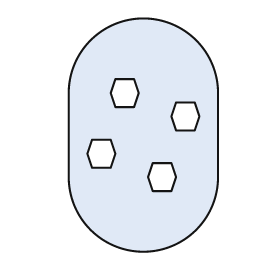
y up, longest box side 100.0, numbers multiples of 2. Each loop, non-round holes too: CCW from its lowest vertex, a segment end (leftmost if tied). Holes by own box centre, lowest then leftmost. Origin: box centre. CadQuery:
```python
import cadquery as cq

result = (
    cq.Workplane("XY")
    .moveTo(-32.0, -18.0)
    .threePointArc((0.0, -50.0), (32.0, -18.0))
    .lineTo(32.0, 18.0)
    .threePointArc((0.0, 50.0), (-32.0, 18.0))
    .close()
    .moveTo(4.0, -24.0)
    .lineTo(12.0, -24.0)
    .lineTo(14.0, -18.0)
    .lineTo(12.0, -12.0)
    .lineTo(4.0, -12.0)
    .lineTo(2.0, -18.0)
    .close()
    .moveTo(-22.0, -14.0)
    .lineTo(-14.0, -14.0)
    .lineTo(-12.0, -8.0)
    .lineTo(-14.0, -2.0)
    .lineTo(-22.0, -2.0)
    .lineTo(-24.0, -8.0)
    .close()
    .moveTo(14.0, 2.0)
    .lineTo(22.0, 2.0)
    .lineTo(24.0, 8.0)
    .lineTo(22.0, 14.0)
    .lineTo(14.0, 14.0)
    .lineTo(12.0, 8.0)
    .close()
    .moveTo(-12.0, 12.0)
    .lineTo(-4.0, 12.0)
    .lineTo(-2.0, 18.0)
    .lineTo(-4.0, 24.0)
    .lineTo(-12.0, 24.0)
    .lineTo(-14.0, 18.0)
    .close()
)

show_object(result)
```